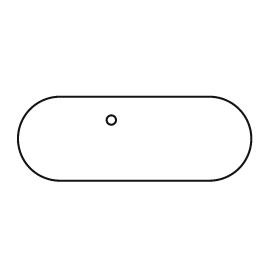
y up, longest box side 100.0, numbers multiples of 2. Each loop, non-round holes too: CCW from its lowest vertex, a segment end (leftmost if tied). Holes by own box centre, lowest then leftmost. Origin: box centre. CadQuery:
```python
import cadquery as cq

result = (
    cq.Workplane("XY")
    .moveTo(-32.0, -18.0)
    .lineTo(32.0, -18.0)
    .threePointArc((50.0, 0.0), (32.0, 18.0))
    .lineTo(-32.0, 18.0)
    .threePointArc((-50.0, 0.0), (-32.0, -18.0))
    .close()
    .moveTo(-10.0, 8.0)
    .circle(2.0)
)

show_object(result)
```